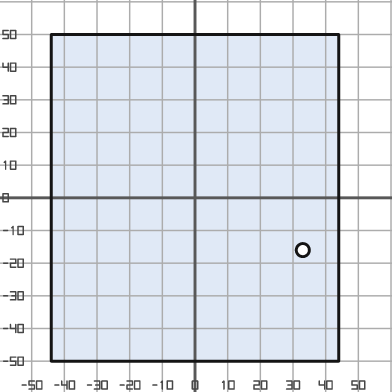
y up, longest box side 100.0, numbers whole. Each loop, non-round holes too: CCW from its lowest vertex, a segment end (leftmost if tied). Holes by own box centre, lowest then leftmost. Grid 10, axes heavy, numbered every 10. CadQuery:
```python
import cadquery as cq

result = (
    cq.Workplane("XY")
    .moveTo(-44.0, -50.0)
    .lineTo(44.0, -50.0)
    .lineTo(44.0, 50.0)
    .lineTo(-44.0, 50.0)
    .close()
    .moveTo(33.0, -16.0)
    .circle(2.0)
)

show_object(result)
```